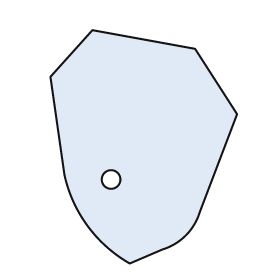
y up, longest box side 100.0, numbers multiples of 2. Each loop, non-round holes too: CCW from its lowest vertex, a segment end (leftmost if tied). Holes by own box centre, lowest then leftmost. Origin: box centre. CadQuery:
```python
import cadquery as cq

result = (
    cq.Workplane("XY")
    .moveTo(-6.0, -50.0)
    .lineTo(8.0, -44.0)
    .threePointArc((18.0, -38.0), (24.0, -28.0))
    .lineTo(40.0, 14.0)
    .lineTo(22.0, 42.0)
    .lineTo(-22.0, 50.0)
    .lineTo(-40.0, 30.0)
    .lineTo(-34.0, -12.0)
    .threePointArc((-24.0, -34.0), (-6.0, -50.0))
    .close()
    .moveTo(-14.0, -14.0)
    .circle(4.0)
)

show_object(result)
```